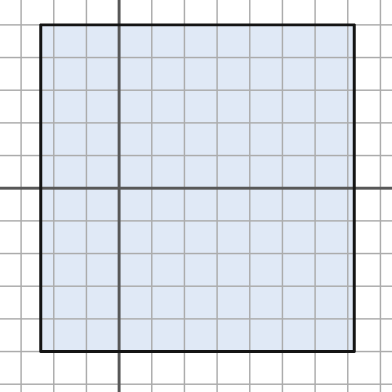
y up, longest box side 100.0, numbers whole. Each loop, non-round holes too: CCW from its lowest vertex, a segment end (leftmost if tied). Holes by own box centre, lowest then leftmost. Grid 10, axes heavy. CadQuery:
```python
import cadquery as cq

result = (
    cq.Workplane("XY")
    .moveTo(-24.0, -50.0)
    .lineTo(72.0, -50.0)
    .lineTo(72.0, 50.0)
    .lineTo(-24.0, 50.0)
    .close()
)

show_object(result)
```